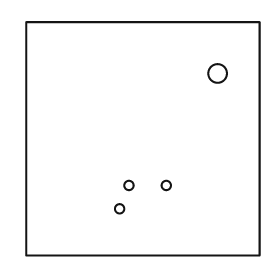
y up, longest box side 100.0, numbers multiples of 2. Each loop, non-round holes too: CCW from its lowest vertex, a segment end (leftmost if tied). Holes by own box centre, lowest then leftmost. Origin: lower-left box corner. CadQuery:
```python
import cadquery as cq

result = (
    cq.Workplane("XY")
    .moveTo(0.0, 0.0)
    .lineTo(100.0, 0.0)
    .lineTo(100.0, 100.0)
    .lineTo(0.0, 100.0)
    .close()
    .moveTo(40.0, 20.0)
    .circle(2.0)
    .moveTo(44.0, 30.0)
    .circle(2.0)
    .moveTo(60.0, 30.0)
    .circle(2.0)
    .moveTo(82.0, 78.0)
    .circle(4.0)
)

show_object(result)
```